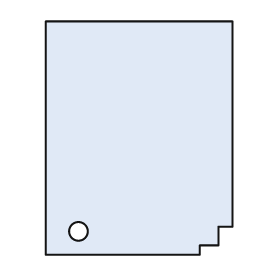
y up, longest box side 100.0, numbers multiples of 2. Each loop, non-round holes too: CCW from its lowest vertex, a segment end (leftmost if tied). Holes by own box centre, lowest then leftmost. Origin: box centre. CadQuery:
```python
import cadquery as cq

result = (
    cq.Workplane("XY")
    .moveTo(-40.0, -50.0)
    .lineTo(26.0, -50.0)
    .lineTo(26.0, -46.0)
    .lineTo(34.0, -46.0)
    .lineTo(34.0, -38.0)
    .lineTo(40.0, -38.0)
    .lineTo(40.0, 50.0)
    .lineTo(-40.0, 50.0)
    .close()
    .moveTo(-26.0, -40.0)
    .circle(4.0)
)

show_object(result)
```